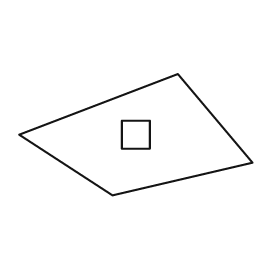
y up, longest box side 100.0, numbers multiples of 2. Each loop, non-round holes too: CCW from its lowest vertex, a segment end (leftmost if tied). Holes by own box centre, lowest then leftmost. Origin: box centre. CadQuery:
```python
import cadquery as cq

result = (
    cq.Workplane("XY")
    .moveTo(-10.0, -26.0)
    .lineTo(50.0, -12.0)
    .lineTo(18.0, 26.0)
    .lineTo(-50.0, 0.0)
    .close()
    .moveTo(-6.0, -6.0)
    .lineTo(6.0, -6.0)
    .lineTo(6.0, 6.0)
    .lineTo(-6.0, 6.0)
    .close()
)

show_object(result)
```